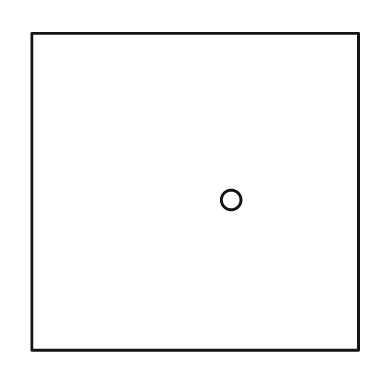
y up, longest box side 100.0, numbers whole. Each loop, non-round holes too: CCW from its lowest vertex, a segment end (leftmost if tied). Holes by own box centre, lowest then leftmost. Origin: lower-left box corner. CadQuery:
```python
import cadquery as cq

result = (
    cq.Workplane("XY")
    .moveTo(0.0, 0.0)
    .lineTo(100.0, 0.0)
    .lineTo(100.0, 97.0)
    .lineTo(0.0, 97.0)
    .close()
    .moveTo(61.0, 46.0)
    .circle(3.0)
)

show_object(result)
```